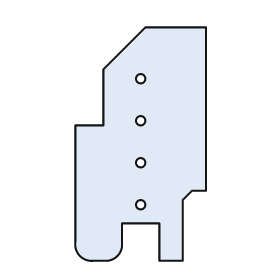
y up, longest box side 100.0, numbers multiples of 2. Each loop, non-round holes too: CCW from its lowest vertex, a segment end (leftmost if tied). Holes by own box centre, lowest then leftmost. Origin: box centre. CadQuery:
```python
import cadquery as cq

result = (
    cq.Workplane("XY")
    .moveTo(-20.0, -50.0)
    .lineTo(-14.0, -50.0)
    .threePointArc((-10.0, -48.0), (-8.0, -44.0))
    .lineTo(-8.0, -34.0)
    .lineTo(8.0, -34.0)
    .lineTo(8.0, -50.0)
    .lineTo(18.0, -50.0)
    .lineTo(18.0, -24.0)
    .lineTo(22.0, -20.0)
    .lineTo(28.0, -20.0)
    .lineTo(28.0, 50.0)
    .lineTo(2.0, 50.0)
    .lineTo(-16.0, 32.0)
    .lineTo(-16.0, 8.0)
    .lineTo(-28.0, 8.0)
    .lineTo(-28.0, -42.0)
    .threePointArc((-26.0, -48.0), (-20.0, -50.0))
    .close()
    .moveTo(0.0, -26.0)
    .circle(2.0)
    .moveTo(0.0, -8.0)
    .circle(2.0)
    .moveTo(0.0, 10.0)
    .circle(2.0)
    .moveTo(0.0, 28.0)
    .circle(2.0)
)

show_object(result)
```